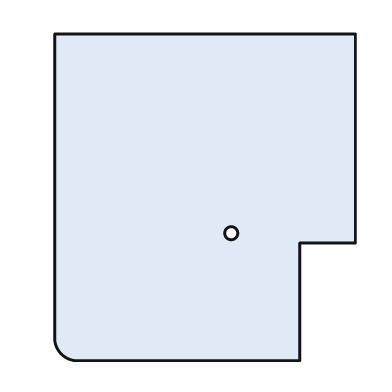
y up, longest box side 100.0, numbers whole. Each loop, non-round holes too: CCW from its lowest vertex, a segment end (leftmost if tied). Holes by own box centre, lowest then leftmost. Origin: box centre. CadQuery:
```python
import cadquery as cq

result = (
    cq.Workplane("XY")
    .moveTo(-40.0, -50.0)
    .lineTo(29.0, -50.0)
    .lineTo(29.0, -14.0)
    .lineTo(46.0, -14.0)
    .lineTo(46.0, 50.0)
    .lineTo(-46.0, 50.0)
    .lineTo(-46.0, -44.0)
    .threePointArc((-44.0, -48.0), (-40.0, -50.0))
    .close()
    .moveTo(8.0, -11.0)
    .circle(2.0)
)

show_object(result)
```